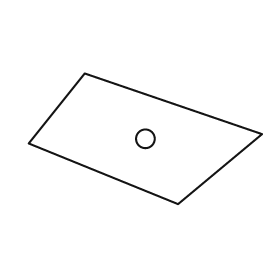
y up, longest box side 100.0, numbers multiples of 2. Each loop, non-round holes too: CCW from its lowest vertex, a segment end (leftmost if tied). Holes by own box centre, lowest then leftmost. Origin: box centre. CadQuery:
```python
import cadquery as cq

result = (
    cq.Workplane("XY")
    .moveTo(14.0, -28.0)
    .lineTo(50.0, 2.0)
    .lineTo(-26.0, 28.0)
    .lineTo(-50.0, -2.0)
    .close()
    .moveTo(0.0, 0.0)
    .circle(4.0)
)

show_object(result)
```